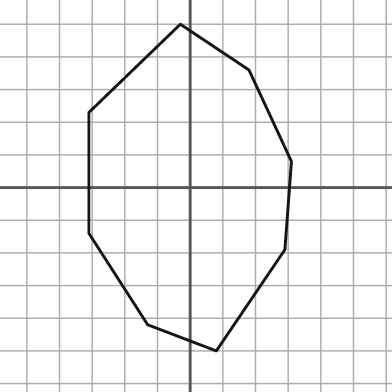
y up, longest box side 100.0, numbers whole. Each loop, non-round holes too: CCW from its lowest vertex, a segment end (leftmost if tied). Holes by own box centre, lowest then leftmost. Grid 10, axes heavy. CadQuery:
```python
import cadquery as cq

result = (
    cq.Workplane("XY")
    .moveTo(8.0, -50.0)
    .lineTo(29.0, -19.0)
    .lineTo(31.0, 8.0)
    .lineTo(18.0, 36.0)
    .lineTo(-3.0, 50.0)
    .lineTo(-31.0, 23.0)
    .lineTo(-31.0, -14.0)
    .lineTo(-13.0, -42.0)
    .close()
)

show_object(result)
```